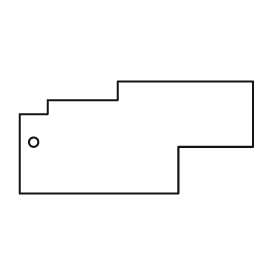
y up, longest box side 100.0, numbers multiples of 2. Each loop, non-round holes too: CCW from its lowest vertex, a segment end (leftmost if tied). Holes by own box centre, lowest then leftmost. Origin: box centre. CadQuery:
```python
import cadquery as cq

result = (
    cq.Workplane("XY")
    .moveTo(-50.0, -24.0)
    .lineTo(18.0, -24.0)
    .lineTo(18.0, -4.0)
    .lineTo(50.0, -4.0)
    .lineTo(50.0, 24.0)
    .lineTo(-8.0, 24.0)
    .lineTo(-8.0, 16.0)
    .lineTo(-38.0, 16.0)
    .lineTo(-38.0, 10.0)
    .lineTo(-50.0, 10.0)
    .close()
    .moveTo(-44.0, -2.0)
    .circle(2.0)
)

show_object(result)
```